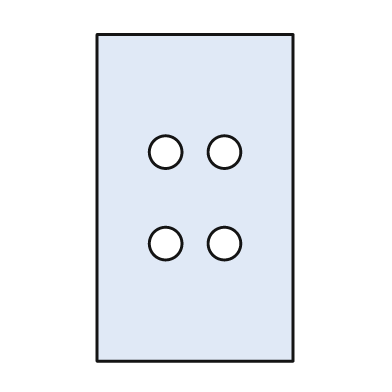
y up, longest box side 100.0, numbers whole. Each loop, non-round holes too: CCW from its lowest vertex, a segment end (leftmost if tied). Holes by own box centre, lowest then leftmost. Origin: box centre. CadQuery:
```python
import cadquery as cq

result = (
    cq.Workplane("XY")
    .moveTo(-30.0, -50.0)
    .lineTo(30.0, -50.0)
    .lineTo(30.0, 50.0)
    .lineTo(-30.0, 50.0)
    .close()
    .moveTo(-9.0, -14.0)
    .circle(5.0)
    .moveTo(9.0, -14.0)
    .circle(5.0)
    .moveTo(-9.0, 14.0)
    .circle(5.0)
    .moveTo(9.0, 14.0)
    .circle(5.0)
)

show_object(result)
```